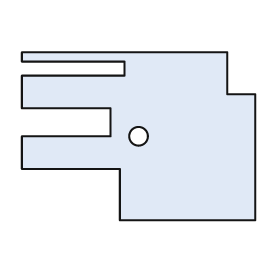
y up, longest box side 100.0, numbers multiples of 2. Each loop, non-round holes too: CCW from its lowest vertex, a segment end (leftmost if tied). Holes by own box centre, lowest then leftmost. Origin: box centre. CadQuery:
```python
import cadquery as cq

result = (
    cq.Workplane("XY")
    .moveTo(-8.0, -36.0)
    .lineTo(50.0, -36.0)
    .lineTo(50.0, 18.0)
    .lineTo(38.0, 18.0)
    .lineTo(38.0, 36.0)
    .lineTo(-50.0, 36.0)
    .lineTo(-50.0, 32.0)
    .lineTo(-6.0, 32.0)
    .lineTo(-6.0, 26.0)
    .lineTo(-50.0, 26.0)
    .lineTo(-50.0, 12.0)
    .lineTo(-12.0, 12.0)
    .lineTo(-12.0, 0.0)
    .lineTo(-50.0, 0.0)
    .lineTo(-50.0, -14.0)
    .lineTo(-8.0, -14.0)
    .close()
    .moveTo(0.0, 0.0)
    .circle(4.0)
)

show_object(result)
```